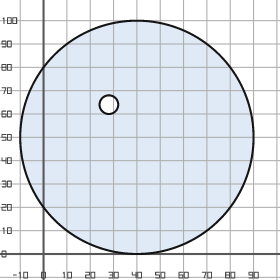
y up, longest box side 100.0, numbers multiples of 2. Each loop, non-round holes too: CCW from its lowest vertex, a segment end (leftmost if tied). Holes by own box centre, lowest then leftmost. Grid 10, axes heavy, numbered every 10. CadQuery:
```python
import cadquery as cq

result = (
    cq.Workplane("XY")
    .moveTo(40.0, 50.0)
    .circle(50.0)
    .moveTo(28.0, 64.0)
    .circle(4.0)
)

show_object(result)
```